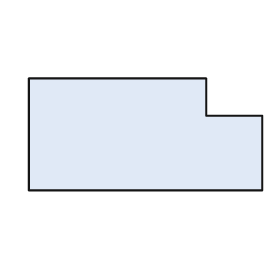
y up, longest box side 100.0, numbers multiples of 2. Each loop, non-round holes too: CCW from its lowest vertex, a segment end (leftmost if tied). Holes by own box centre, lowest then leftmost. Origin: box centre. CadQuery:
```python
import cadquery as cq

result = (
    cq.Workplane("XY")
    .moveTo(-50.0, -24.0)
    .lineTo(50.0, -24.0)
    .lineTo(50.0, 8.0)
    .lineTo(26.0, 8.0)
    .lineTo(26.0, 24.0)
    .lineTo(-50.0, 24.0)
    .close()
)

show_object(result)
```